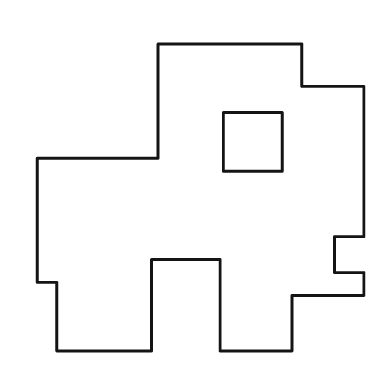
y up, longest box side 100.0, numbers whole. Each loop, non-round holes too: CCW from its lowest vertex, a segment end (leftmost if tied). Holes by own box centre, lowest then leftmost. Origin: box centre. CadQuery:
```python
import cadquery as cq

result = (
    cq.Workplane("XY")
    .moveTo(-44.0, -47.0)
    .lineTo(-15.0, -47.0)
    .lineTo(-15.0, -19.0)
    .lineTo(6.0, -19.0)
    .lineTo(6.0, -47.0)
    .lineTo(28.0, -47.0)
    .lineTo(28.0, -30.0)
    .lineTo(50.0, -30.0)
    .lineTo(50.0, -23.0)
    .lineTo(41.0, -23.0)
    .lineTo(41.0, -12.0)
    .lineTo(50.0, -12.0)
    .lineTo(50.0, 34.0)
    .lineTo(31.0, 34.0)
    .lineTo(31.0, 47.0)
    .lineTo(-13.0, 47.0)
    .lineTo(-13.0, 12.0)
    .lineTo(-50.0, 12.0)
    .lineTo(-50.0, -26.0)
    .lineTo(-44.0, -26.0)
    .close()
    .moveTo(7.0, 8.0)
    .lineTo(25.0, 8.0)
    .lineTo(25.0, 26.0)
    .lineTo(7.0, 26.0)
    .close()
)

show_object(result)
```